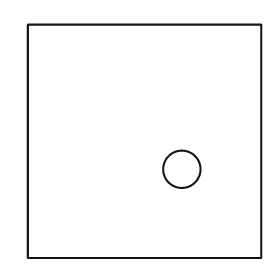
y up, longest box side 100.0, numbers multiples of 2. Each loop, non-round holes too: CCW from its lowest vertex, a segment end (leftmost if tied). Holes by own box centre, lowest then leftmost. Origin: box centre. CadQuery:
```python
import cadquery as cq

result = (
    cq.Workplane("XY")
    .moveTo(-50.0, -50.0)
    .lineTo(50.0, -50.0)
    .lineTo(50.0, 50.0)
    .lineTo(-50.0, 50.0)
    .close()
    .moveTo(16.0, -12.0)
    .circle(8.0)
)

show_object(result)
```